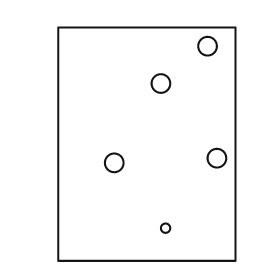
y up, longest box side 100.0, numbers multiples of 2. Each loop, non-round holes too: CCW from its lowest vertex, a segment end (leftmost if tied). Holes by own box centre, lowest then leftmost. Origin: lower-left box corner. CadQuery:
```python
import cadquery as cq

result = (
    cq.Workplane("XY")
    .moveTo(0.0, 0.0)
    .lineTo(76.0, 0.0)
    .lineTo(76.0, 100.0)
    .lineTo(0.0, 100.0)
    .close()
    .moveTo(46.0, 14.0)
    .circle(2.0)
    .moveTo(24.0, 42.0)
    .circle(4.0)
    .moveTo(68.0, 44.0)
    .circle(4.0)
    .moveTo(44.0, 76.0)
    .circle(4.0)
    .moveTo(64.0, 92.0)
    .circle(4.0)
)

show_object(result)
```